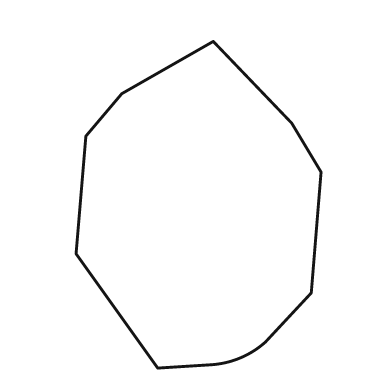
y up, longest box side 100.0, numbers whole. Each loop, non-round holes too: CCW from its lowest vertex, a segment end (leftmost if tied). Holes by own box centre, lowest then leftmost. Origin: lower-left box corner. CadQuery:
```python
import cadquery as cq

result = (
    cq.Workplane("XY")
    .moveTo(25.0, 0.0)
    .lineTo(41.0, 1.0)
    .threePointArc((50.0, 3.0), (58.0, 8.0))
    .lineTo(72.0, 23.0)
    .lineTo(75.0, 60.0)
    .lineTo(66.0, 75.0)
    .lineTo(42.0, 100.0)
    .lineTo(14.0, 84.0)
    .lineTo(3.0, 71.0)
    .lineTo(0.0, 35.0)
    .close()
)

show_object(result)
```